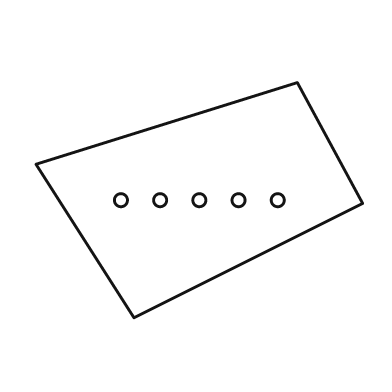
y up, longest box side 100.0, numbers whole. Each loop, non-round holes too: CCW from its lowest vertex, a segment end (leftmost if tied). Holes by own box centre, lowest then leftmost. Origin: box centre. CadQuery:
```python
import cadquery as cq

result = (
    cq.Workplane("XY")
    .moveTo(-20.0, -36.0)
    .lineTo(50.0, -1.0)
    .lineTo(30.0, 36.0)
    .lineTo(-50.0, 11.0)
    .close()
    .moveTo(-24.0, 0.0)
    .circle(2.0)
    .moveTo(-12.0, 0.0)
    .circle(2.0)
    .moveTo(0.0, 0.0)
    .circle(2.0)
    .moveTo(12.0, 0.0)
    .circle(2.0)
    .moveTo(24.0, 0.0)
    .circle(2.0)
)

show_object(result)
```